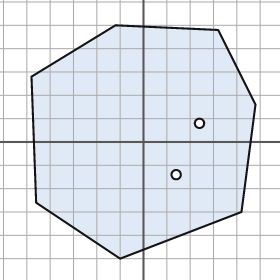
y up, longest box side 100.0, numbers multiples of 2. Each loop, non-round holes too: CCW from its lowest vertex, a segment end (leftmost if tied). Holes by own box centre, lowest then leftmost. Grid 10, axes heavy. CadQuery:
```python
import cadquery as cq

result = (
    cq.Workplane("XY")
    .moveTo(-10.0, -50.0)
    .lineTo(42.0, -30.0)
    .lineTo(48.0, 16.0)
    .lineTo(32.0, 48.0)
    .lineTo(-12.0, 50.0)
    .lineTo(-48.0, 28.0)
    .lineTo(-46.0, -26.0)
    .close()
    .moveTo(14.0, -14.0)
    .circle(2.0)
    .moveTo(24.0, 8.0)
    .circle(2.0)
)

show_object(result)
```